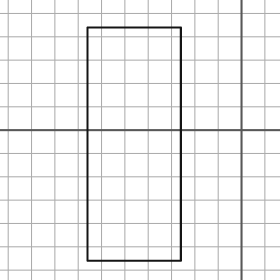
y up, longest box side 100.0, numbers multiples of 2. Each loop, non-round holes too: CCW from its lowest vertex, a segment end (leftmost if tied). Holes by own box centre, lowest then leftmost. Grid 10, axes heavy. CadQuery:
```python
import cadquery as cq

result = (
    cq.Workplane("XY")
    .moveTo(-66.0, -56.0)
    .lineTo(-26.0, -56.0)
    .lineTo(-26.0, 44.0)
    .lineTo(-66.0, 44.0)
    .close()
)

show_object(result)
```